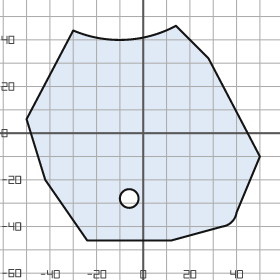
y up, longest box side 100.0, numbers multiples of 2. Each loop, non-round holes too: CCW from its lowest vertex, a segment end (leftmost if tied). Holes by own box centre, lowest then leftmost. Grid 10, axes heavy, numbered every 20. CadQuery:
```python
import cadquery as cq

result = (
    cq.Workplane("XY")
    .moveTo(-24.0, -46.0)
    .lineTo(12.0, -46.0)
    .lineTo(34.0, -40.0)
    .threePointArc((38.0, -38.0), (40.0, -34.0))
    .lineTo(50.0, -10.0)
    .lineTo(28.0, 32.0)
    .lineTo(14.0, 46.0)
    .threePointArc((-8.0, 40.0), (-30.0, 44.0))
    .lineTo(-50.0, 6.0)
    .lineTo(-42.0, -20.0)
    .close()
    .moveTo(-6.0, -28.0)
    .circle(4.0)
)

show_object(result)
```